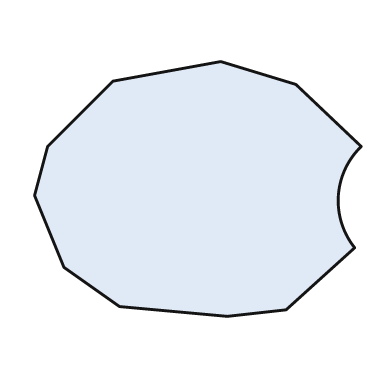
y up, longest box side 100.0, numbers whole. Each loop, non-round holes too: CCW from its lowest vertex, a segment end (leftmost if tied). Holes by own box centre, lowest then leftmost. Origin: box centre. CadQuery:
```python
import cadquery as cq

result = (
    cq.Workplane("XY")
    .moveTo(9.0, -39.0)
    .lineTo(27.0, -37.0)
    .lineTo(48.0, -18.0)
    .threePointArc((43.0, -2.0), (50.0, 13.0))
    .lineTo(30.0, 32.0)
    .lineTo(7.0, 39.0)
    .lineTo(-26.0, 33.0)
    .lineTo(-46.0, 13.0)
    .lineTo(-50.0, -2.0)
    .lineTo(-41.0, -24.0)
    .lineTo(-24.0, -36.0)
    .close()
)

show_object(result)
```